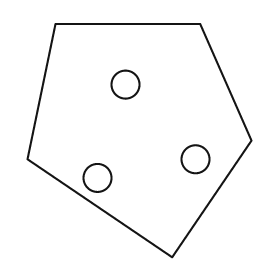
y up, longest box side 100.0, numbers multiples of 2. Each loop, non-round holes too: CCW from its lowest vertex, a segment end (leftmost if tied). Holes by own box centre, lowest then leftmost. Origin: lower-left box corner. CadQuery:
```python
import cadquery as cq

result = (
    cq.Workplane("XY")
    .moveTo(62.0, 0.0)
    .lineTo(96.0, 50.0)
    .lineTo(74.0, 100.0)
    .lineTo(12.0, 100.0)
    .lineTo(0.0, 42.0)
    .close()
    .moveTo(30.0, 34.0)
    .circle(6.0)
    .moveTo(72.0, 42.0)
    .circle(6.0)
    .moveTo(42.0, 74.0)
    .circle(6.0)
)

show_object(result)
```